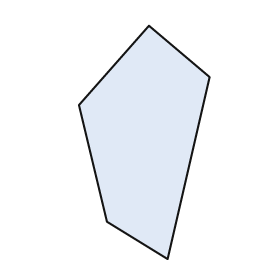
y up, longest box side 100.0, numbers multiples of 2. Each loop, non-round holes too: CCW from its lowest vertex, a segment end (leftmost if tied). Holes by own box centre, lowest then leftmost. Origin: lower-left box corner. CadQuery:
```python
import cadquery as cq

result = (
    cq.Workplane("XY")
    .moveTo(38.0, 0.0)
    .lineTo(56.0, 78.0)
    .lineTo(30.0, 100.0)
    .lineTo(0.0, 66.0)
    .lineTo(12.0, 16.0)
    .close()
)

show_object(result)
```